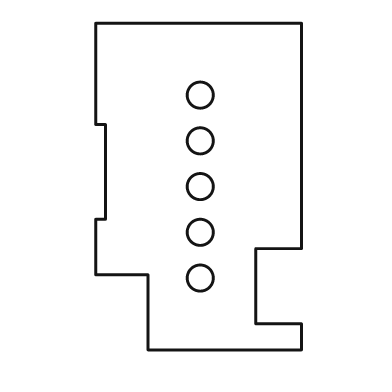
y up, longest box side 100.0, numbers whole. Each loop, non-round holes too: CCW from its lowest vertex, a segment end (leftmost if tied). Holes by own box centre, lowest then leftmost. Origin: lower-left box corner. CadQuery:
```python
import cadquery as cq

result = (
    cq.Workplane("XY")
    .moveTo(16.0, 0.0)
    .lineTo(63.0, 0.0)
    .lineTo(63.0, 8.0)
    .lineTo(49.0, 8.0)
    .lineTo(49.0, 31.0)
    .lineTo(63.0, 31.0)
    .lineTo(63.0, 100.0)
    .lineTo(0.0, 100.0)
    .lineTo(0.0, 69.0)
    .lineTo(3.0, 69.0)
    .lineTo(3.0, 40.0)
    .lineTo(0.0, 40.0)
    .lineTo(0.0, 23.0)
    .lineTo(16.0, 23.0)
    .close()
    .moveTo(32.0, 22.0)
    .circle(4.0)
    .moveTo(32.0, 36.0)
    .circle(4.0)
    .moveTo(32.0, 50.0)
    .circle(4.0)
    .moveTo(32.0, 64.0)
    .circle(4.0)
    .moveTo(32.0, 78.0)
    .circle(4.0)
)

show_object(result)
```